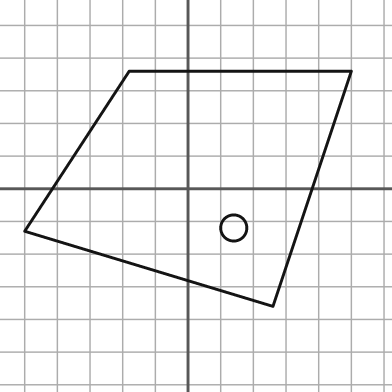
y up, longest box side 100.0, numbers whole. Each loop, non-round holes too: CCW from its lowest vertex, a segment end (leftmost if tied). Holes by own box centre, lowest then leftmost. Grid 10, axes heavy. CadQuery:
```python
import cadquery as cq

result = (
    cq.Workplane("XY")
    .moveTo(26.0, -36.0)
    .lineTo(50.0, 36.0)
    .lineTo(-18.0, 36.0)
    .lineTo(-50.0, -13.0)
    .close()
    .moveTo(14.0, -12.0)
    .circle(4.0)
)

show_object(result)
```